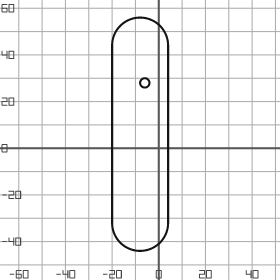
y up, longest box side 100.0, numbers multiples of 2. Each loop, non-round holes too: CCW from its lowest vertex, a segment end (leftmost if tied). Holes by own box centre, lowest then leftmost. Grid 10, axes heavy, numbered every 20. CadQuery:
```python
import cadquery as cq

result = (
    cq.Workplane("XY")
    .moveTo(-20.0, -32.0)
    .threePointArc((-8.0, -44.0), (4.0, -32.0))
    .lineTo(4.0, 44.0)
    .threePointArc((-8.0, 56.0), (-20.0, 44.0))
    .close()
    .moveTo(-6.0, 28.0)
    .circle(2.0)
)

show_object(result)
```